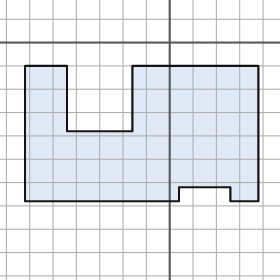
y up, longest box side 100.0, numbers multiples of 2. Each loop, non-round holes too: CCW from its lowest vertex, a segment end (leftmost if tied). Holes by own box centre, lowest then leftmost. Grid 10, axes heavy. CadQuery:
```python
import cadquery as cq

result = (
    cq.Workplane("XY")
    .moveTo(-62.0, -68.0)
    .lineTo(4.0, -68.0)
    .lineTo(4.0, -62.0)
    .lineTo(26.0, -62.0)
    .lineTo(26.0, -68.0)
    .lineTo(38.0, -68.0)
    .lineTo(38.0, -10.0)
    .lineTo(-16.0, -10.0)
    .lineTo(-16.0, -38.0)
    .lineTo(-44.0, -38.0)
    .lineTo(-44.0, -10.0)
    .lineTo(-62.0, -10.0)
    .close()
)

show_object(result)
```